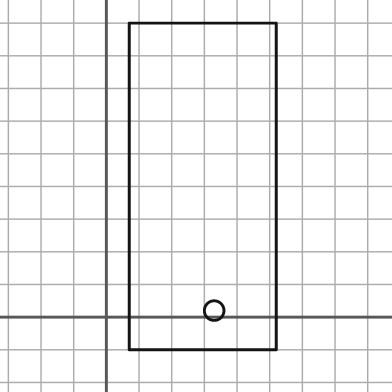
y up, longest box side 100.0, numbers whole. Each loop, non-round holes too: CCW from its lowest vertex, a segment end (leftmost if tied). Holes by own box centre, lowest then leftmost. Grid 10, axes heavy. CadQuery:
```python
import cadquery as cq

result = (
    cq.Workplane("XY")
    .moveTo(7.0, -10.0)
    .lineTo(52.0, -10.0)
    .lineTo(52.0, 90.0)
    .lineTo(7.0, 90.0)
    .close()
    .moveTo(33.0, 2.0)
    .circle(3.0)
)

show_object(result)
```